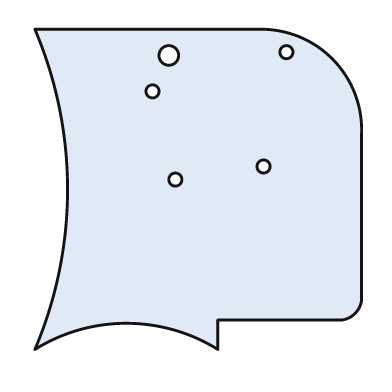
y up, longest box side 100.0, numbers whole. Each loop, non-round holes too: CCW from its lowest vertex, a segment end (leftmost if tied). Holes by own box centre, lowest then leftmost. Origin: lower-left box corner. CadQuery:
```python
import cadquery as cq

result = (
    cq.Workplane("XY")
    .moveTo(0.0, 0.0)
    .threePointArc((28.0, 8.0), (56.0, 0.0))
    .lineTo(56.0, 9.0)
    .lineTo(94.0, 9.0)
    .threePointArc((98.0, 11.0), (100.0, 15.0))
    .lineTo(100.0, 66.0)
    .threePointArc((91.0, 89.0), (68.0, 98.0))
    .lineTo(0.0, 98.0)
    .threePointArc((10.0, 49.0), (0.0, 0.0))
    .close()
    .moveTo(43.0, 52.0)
    .circle(2.0)
    .moveTo(70.0, 56.0)
    .circle(2.0)
    .moveTo(36.0, 79.0)
    .circle(2.0)
    .moveTo(41.0, 90.0)
    .circle(3.0)
    .moveTo(77.0, 91.0)
    .circle(2.0)
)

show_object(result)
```